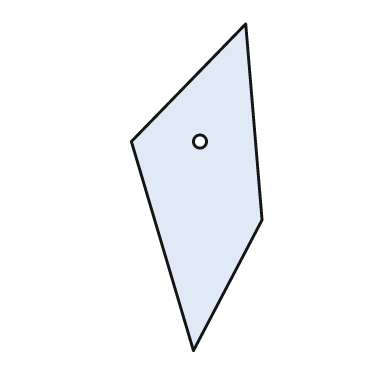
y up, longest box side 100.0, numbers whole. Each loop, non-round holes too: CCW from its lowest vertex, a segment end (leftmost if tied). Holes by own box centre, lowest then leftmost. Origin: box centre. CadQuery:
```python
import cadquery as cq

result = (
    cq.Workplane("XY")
    .moveTo(-1.0, -50.0)
    .lineTo(20.0, -10.0)
    .lineTo(15.0, 50.0)
    .lineTo(-20.0, 14.0)
    .close()
    .moveTo(1.0, 14.0)
    .circle(2.0)
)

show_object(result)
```